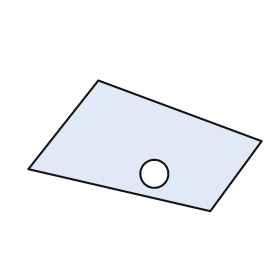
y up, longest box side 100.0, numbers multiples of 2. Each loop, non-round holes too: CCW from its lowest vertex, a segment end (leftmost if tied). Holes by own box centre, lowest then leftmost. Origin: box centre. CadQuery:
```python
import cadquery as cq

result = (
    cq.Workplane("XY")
    .moveTo(28.0, -28.0)
    .lineTo(50.0, 2.0)
    .lineTo(-20.0, 28.0)
    .lineTo(-50.0, -10.0)
    .close()
    .moveTo(4.0, -12.0)
    .circle(6.0)
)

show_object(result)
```